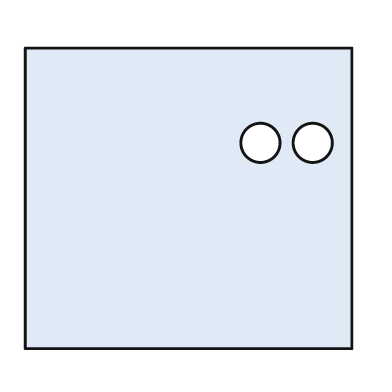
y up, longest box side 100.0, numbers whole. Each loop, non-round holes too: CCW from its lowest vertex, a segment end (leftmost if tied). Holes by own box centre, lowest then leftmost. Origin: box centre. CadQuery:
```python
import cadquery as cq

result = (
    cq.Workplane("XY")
    .moveTo(-50.0, -46.0)
    .lineTo(50.0, -46.0)
    .lineTo(50.0, 46.0)
    .lineTo(-50.0, 46.0)
    .close()
    .moveTo(22.0, 17.0)
    .circle(6.0)
    .moveTo(38.0, 17.0)
    .circle(6.0)
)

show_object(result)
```